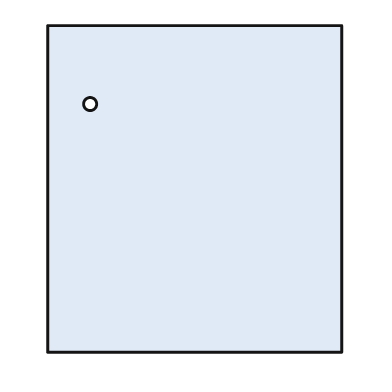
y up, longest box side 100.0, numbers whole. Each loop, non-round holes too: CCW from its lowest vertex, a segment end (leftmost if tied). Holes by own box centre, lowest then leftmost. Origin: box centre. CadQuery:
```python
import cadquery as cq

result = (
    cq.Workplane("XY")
    .moveTo(-45.0, -50.0)
    .lineTo(45.0, -50.0)
    .lineTo(45.0, 50.0)
    .lineTo(-45.0, 50.0)
    .close()
    .moveTo(-32.0, 26.0)
    .circle(2.0)
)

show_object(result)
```